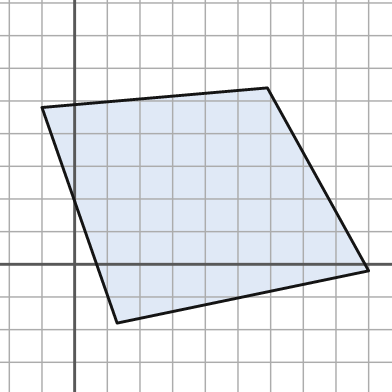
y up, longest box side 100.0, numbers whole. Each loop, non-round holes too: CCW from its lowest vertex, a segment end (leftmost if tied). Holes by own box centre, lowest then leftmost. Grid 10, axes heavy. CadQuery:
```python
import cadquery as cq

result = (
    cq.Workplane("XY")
    .moveTo(13.0, -18.0)
    .lineTo(90.0, -2.0)
    .lineTo(59.0, 54.0)
    .lineTo(-10.0, 48.0)
    .close()
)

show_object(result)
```